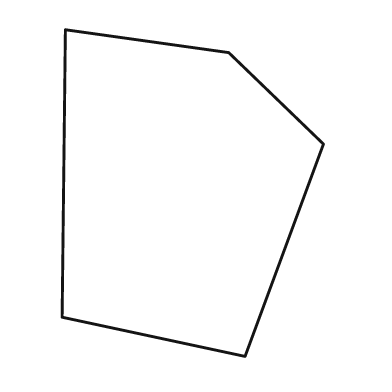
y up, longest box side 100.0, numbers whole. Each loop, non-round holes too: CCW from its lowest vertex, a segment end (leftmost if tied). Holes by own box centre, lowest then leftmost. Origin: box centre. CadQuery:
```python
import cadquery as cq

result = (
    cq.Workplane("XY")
    .moveTo(16.0, -50.0)
    .lineTo(40.0, 15.0)
    .lineTo(11.0, 43.0)
    .lineTo(-39.0, 50.0)
    .lineTo(-40.0, -38.0)
    .close()
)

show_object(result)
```